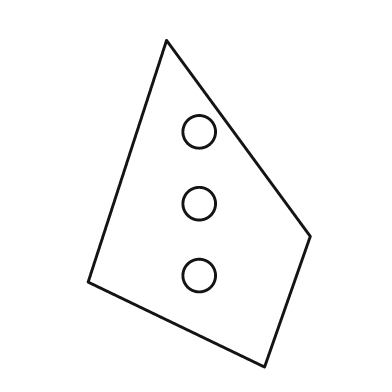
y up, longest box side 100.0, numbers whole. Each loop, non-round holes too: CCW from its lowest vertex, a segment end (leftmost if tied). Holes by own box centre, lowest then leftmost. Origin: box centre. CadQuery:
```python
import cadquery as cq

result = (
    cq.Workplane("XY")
    .moveTo(20.0, -50.0)
    .lineTo(34.0, -10.0)
    .lineTo(-10.0, 50.0)
    .lineTo(-34.0, -24.0)
    .close()
    .moveTo(0.0, -22.0)
    .circle(5.0)
    .moveTo(0.0, 0.0)
    .circle(5.0)
    .moveTo(0.0, 22.0)
    .circle(5.0)
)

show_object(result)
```